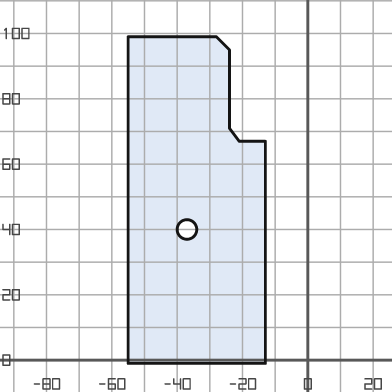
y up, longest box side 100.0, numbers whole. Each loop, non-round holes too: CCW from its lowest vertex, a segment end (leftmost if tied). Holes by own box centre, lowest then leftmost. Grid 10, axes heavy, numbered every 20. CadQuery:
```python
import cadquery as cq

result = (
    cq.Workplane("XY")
    .moveTo(-55.0, -1.0)
    .lineTo(-13.0, -1.0)
    .lineTo(-13.0, 67.0)
    .lineTo(-21.0, 67.0)
    .lineTo(-24.0, 71.0)
    .lineTo(-24.0, 95.0)
    .lineTo(-28.0, 99.0)
    .lineTo(-55.0, 99.0)
    .close()
    .moveTo(-37.0, 40.0)
    .circle(3.0)
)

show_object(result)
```